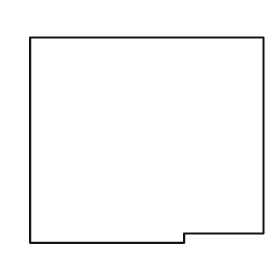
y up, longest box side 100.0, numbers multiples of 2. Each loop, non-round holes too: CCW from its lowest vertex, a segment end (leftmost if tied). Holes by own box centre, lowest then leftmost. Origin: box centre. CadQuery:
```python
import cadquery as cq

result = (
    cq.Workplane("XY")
    .moveTo(-50.0, -44.0)
    .lineTo(16.0, -44.0)
    .lineTo(16.0, -40.0)
    .lineTo(50.0, -40.0)
    .lineTo(50.0, 44.0)
    .lineTo(-50.0, 44.0)
    .close()
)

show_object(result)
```